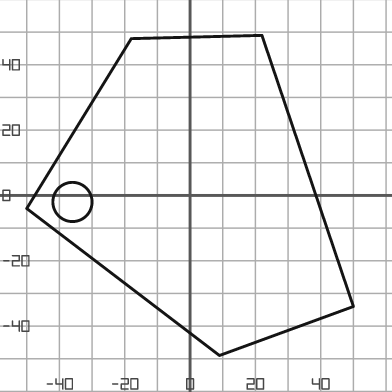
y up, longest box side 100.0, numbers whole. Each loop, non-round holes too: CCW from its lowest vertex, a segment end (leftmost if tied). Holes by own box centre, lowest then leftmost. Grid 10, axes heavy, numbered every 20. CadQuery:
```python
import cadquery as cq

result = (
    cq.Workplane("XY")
    .moveTo(9.0, -49.0)
    .lineTo(50.0, -34.0)
    .lineTo(22.0, 49.0)
    .lineTo(-18.0, 48.0)
    .lineTo(-50.0, -4.0)
    .close()
    .moveTo(-36.0, -2.0)
    .circle(6.0)
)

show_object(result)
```